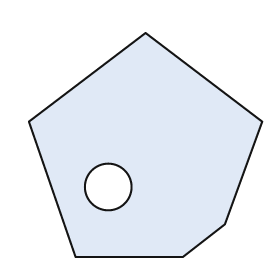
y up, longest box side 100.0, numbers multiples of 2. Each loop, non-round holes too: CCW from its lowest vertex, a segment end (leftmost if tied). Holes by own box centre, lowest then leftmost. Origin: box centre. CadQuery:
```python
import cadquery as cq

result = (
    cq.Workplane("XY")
    .moveTo(-30.0, -48.0)
    .lineTo(16.0, -48.0)
    .lineTo(34.0, -34.0)
    .lineTo(50.0, 10.0)
    .lineTo(0.0, 48.0)
    .lineTo(-50.0, 10.0)
    .close()
    .moveTo(-16.0, -18.0)
    .circle(10.0)
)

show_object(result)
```